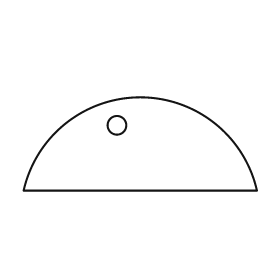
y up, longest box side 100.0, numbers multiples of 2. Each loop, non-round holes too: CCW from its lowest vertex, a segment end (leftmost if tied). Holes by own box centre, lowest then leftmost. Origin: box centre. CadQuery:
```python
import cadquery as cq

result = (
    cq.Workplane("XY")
    .moveTo(-50.0, -20.0)
    .lineTo(50.0, -20.0)
    .threePointArc((0.0, 20.0), (-50.0, -20.0))
    .close()
    .moveTo(-10.0, 8.0)
    .circle(4.0)
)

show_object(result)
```